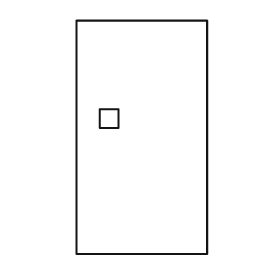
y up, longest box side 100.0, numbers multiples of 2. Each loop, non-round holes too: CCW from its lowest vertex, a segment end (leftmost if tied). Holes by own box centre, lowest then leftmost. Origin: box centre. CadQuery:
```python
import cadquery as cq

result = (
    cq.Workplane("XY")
    .moveTo(-28.0, -50.0)
    .lineTo(28.0, -50.0)
    .lineTo(28.0, 50.0)
    .lineTo(-28.0, 50.0)
    .close()
    .moveTo(-18.0, 4.0)
    .lineTo(-10.0, 4.0)
    .lineTo(-10.0, 12.0)
    .lineTo(-18.0, 12.0)
    .close()
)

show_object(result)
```